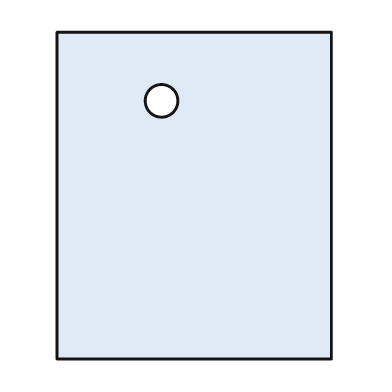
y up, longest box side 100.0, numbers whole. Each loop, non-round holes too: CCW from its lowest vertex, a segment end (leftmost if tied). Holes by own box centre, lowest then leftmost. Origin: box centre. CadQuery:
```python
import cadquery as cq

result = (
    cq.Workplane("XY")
    .moveTo(-42.0, -50.0)
    .lineTo(42.0, -50.0)
    .lineTo(42.0, 50.0)
    .lineTo(-42.0, 50.0)
    .close()
    .moveTo(-10.0, 29.0)
    .circle(5.0)
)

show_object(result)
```